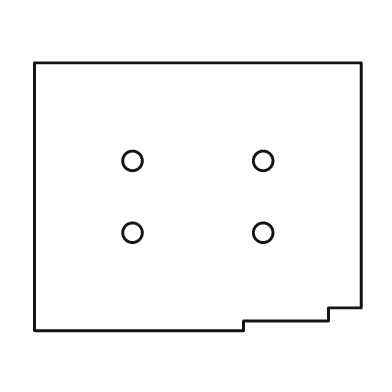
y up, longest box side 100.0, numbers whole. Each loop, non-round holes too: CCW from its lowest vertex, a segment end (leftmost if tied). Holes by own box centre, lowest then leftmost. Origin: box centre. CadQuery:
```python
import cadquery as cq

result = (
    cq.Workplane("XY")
    .moveTo(-50.0, -41.0)
    .lineTo(14.0, -41.0)
    .lineTo(14.0, -38.0)
    .lineTo(40.0, -38.0)
    .lineTo(40.0, -34.0)
    .lineTo(50.0, -34.0)
    .lineTo(50.0, 41.0)
    .lineTo(-50.0, 41.0)
    .close()
    .moveTo(-20.0, -11.0)
    .circle(3.0)
    .moveTo(20.0, -11.0)
    .circle(3.0)
    .moveTo(-20.0, 11.0)
    .circle(3.0)
    .moveTo(20.0, 11.0)
    .circle(3.0)
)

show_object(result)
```